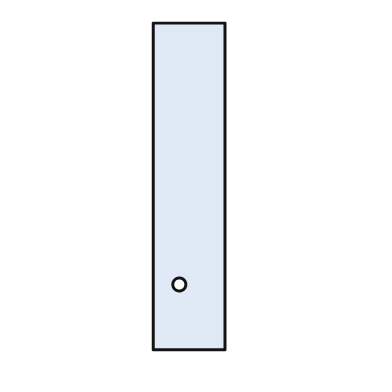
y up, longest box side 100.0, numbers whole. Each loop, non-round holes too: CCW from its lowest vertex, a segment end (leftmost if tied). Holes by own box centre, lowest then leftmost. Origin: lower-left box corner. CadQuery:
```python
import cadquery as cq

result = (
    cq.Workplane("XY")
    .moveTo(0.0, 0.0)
    .lineTo(22.0, 0.0)
    .lineTo(22.0, 100.0)
    .lineTo(0.0, 100.0)
    .close()
    .moveTo(8.0, 20.0)
    .circle(2.0)
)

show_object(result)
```